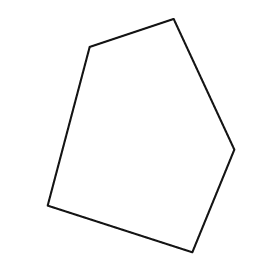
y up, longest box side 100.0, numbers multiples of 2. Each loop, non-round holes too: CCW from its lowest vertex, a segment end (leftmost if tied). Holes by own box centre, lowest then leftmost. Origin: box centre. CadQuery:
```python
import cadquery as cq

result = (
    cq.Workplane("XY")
    .moveTo(22.0, -50.0)
    .lineTo(40.0, -6.0)
    .lineTo(14.0, 50.0)
    .lineTo(-22.0, 38.0)
    .lineTo(-40.0, -30.0)
    .close()
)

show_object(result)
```